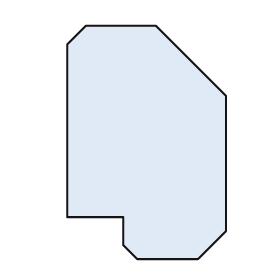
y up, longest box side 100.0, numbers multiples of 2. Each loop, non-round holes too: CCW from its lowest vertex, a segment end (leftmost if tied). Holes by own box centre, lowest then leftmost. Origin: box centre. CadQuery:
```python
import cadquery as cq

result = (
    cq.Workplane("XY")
    .moveTo(-4.0, -50.0)
    .lineTo(22.0, -50.0)
    .lineTo(34.0, -38.0)
    .lineTo(34.0, 20.0)
    .lineTo(4.0, 50.0)
    .lineTo(-26.0, 50.0)
    .lineTo(-34.0, 42.0)
    .lineTo(-34.0, -32.0)
    .lineTo(-10.0, -32.0)
    .lineTo(-10.0, -44.0)
    .close()
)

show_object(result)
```